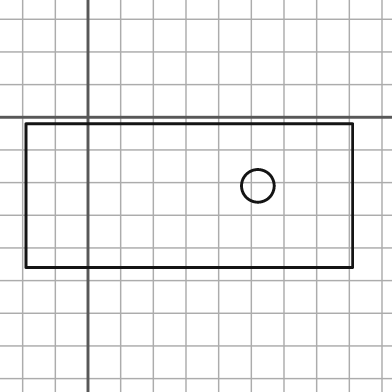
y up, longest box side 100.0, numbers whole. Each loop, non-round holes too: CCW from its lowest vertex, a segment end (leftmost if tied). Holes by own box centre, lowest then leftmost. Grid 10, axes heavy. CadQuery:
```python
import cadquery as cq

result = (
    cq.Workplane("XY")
    .moveTo(-19.0, -46.0)
    .lineTo(81.0, -46.0)
    .lineTo(81.0, -2.0)
    .lineTo(-19.0, -2.0)
    .close()
    .moveTo(52.0, -21.0)
    .circle(5.0)
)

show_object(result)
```